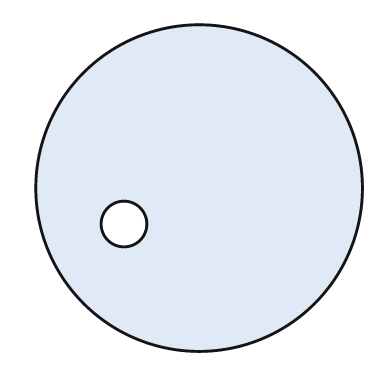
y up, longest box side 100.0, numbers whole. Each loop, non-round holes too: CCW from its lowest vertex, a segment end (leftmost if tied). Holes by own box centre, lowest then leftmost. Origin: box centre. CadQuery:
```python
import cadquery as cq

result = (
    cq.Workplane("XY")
    .moveTo(0.0, 0.0)
    .circle(50.0)
    .moveTo(-23.0, -11.0)
    .circle(7.0)
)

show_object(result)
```